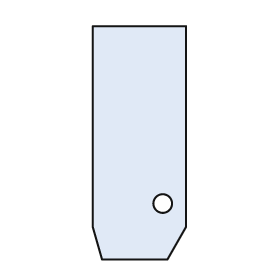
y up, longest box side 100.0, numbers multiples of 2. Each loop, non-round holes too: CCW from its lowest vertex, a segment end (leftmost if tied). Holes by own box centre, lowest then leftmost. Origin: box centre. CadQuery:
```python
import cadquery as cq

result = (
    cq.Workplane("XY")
    .moveTo(-16.0, -50.0)
    .lineTo(12.0, -50.0)
    .lineTo(20.0, -36.0)
    .lineTo(20.0, 50.0)
    .lineTo(-20.0, 50.0)
    .lineTo(-20.0, -36.0)
    .close()
    .moveTo(10.0, -26.0)
    .circle(4.0)
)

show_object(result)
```